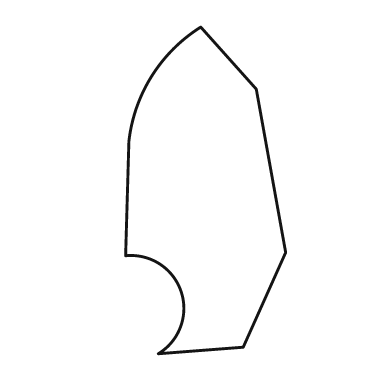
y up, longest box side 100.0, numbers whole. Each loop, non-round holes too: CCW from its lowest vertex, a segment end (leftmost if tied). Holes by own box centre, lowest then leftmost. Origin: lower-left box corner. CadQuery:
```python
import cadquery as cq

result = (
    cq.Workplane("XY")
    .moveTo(10.0, 0.0)
    .lineTo(36.0, 2.0)
    .lineTo(49.0, 31.0)
    .lineTo(40.0, 81.0)
    .lineTo(23.0, 100.0)
    .threePointArc((8.0, 85.0), (1.0, 65.0))
    .lineTo(0.0, 30.0)
    .threePointArc((17.0, 19.0), (10.0, 0.0))
    .close()
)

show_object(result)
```